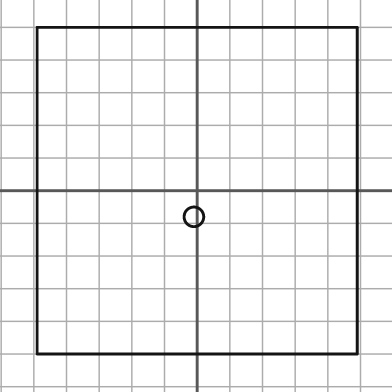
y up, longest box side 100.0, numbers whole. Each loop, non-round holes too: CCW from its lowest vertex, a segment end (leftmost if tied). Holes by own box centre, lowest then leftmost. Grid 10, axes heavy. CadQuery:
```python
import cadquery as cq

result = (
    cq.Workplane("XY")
    .moveTo(-49.0, -50.0)
    .lineTo(49.0, -50.0)
    .lineTo(49.0, 50.0)
    .lineTo(-49.0, 50.0)
    .close()
    .moveTo(-1.0, -8.0)
    .circle(3.0)
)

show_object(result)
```